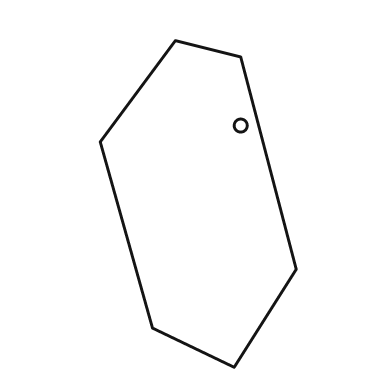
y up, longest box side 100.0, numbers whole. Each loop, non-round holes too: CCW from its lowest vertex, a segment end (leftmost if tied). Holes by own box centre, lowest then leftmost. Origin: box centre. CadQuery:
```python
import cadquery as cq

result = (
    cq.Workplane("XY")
    .moveTo(11.0, -50.0)
    .lineTo(30.0, -20.0)
    .lineTo(13.0, 45.0)
    .lineTo(-7.0, 50.0)
    .lineTo(-30.0, 19.0)
    .lineTo(-14.0, -38.0)
    .close()
    .moveTo(13.0, 24.0)
    .circle(2.0)
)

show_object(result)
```